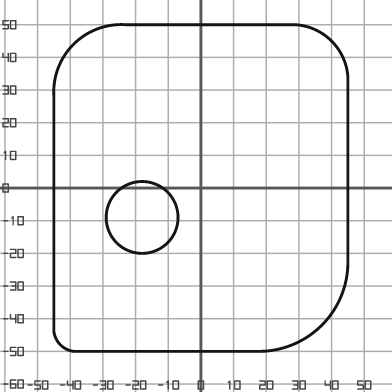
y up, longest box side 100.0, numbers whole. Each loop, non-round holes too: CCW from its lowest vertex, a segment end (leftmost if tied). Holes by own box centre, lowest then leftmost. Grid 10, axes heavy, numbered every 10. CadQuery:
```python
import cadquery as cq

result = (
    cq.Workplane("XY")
    .moveTo(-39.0, -50.0)
    .lineTo(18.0, -50.0)
    .threePointArc((37.0, -42.0), (45.0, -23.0))
    .lineTo(45.0, 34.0)
    .threePointArc((40.0, 45.0), (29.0, 50.0))
    .lineTo(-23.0, 50.0)
    .threePointArc((-39.0, 44.0), (-45.0, 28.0))
    .lineTo(-45.0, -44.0)
    .threePointArc((-43.0, -48.0), (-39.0, -50.0))
    .close()
    .moveTo(-18.0, -9.0)
    .circle(11.0)
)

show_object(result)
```